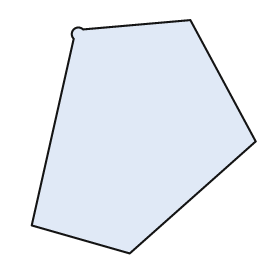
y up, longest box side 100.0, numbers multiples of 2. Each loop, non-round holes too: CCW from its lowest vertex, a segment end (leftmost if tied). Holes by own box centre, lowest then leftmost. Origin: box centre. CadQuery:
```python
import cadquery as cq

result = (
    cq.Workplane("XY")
    .moveTo(-6.0, -50.0)
    .lineTo(48.0, -2.0)
    .lineTo(20.0, 50.0)
    .lineTo(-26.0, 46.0)
    .threePointArc((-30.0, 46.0), (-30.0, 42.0))
    .lineTo(-48.0, -38.0)
    .close()
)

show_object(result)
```